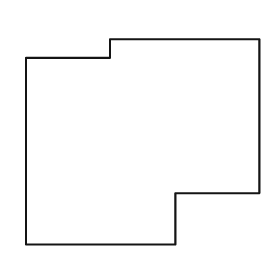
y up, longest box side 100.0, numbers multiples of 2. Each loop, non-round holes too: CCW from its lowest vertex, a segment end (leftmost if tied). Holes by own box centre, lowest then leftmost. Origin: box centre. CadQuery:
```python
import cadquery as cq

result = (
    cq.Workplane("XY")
    .moveTo(-50.0, -44.0)
    .lineTo(14.0, -44.0)
    .lineTo(14.0, -22.0)
    .lineTo(50.0, -22.0)
    .lineTo(50.0, 44.0)
    .lineTo(-14.0, 44.0)
    .lineTo(-14.0, 36.0)
    .lineTo(-50.0, 36.0)
    .close()
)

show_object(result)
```